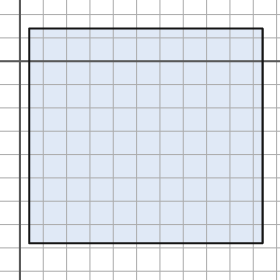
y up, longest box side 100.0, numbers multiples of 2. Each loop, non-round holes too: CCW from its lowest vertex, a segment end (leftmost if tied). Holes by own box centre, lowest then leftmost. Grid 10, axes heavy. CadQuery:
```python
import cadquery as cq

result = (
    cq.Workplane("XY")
    .moveTo(4.0, -78.0)
    .lineTo(104.0, -78.0)
    .lineTo(104.0, 14.0)
    .lineTo(4.0, 14.0)
    .close()
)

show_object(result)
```